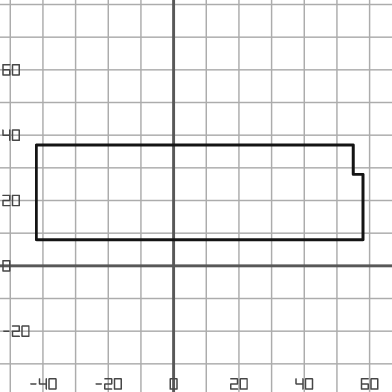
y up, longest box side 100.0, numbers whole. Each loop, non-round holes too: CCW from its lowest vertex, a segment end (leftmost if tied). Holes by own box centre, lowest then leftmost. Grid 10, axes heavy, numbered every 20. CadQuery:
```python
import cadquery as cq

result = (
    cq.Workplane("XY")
    .moveTo(-42.0, 8.0)
    .lineTo(58.0, 8.0)
    .lineTo(58.0, 28.0)
    .lineTo(55.0, 28.0)
    .lineTo(55.0, 37.0)
    .lineTo(-42.0, 37.0)
    .close()
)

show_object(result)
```